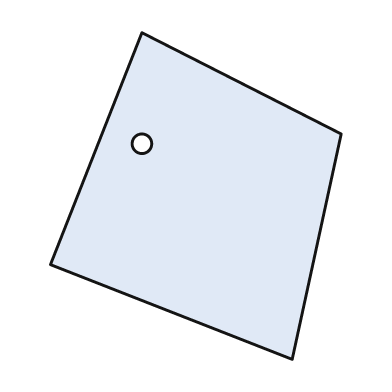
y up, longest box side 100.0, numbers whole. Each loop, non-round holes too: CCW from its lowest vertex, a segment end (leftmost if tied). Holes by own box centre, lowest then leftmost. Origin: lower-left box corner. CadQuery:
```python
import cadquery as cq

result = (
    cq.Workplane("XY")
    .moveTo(74.0, 0.0)
    .lineTo(89.0, 69.0)
    .lineTo(28.0, 100.0)
    .lineTo(0.0, 29.0)
    .close()
    .moveTo(28.0, 66.0)
    .circle(3.0)
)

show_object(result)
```